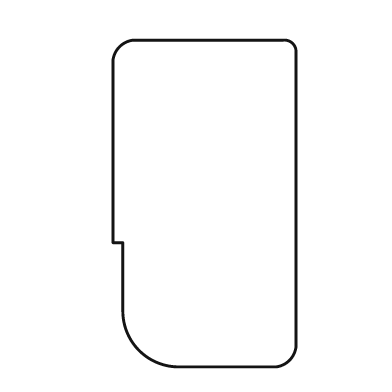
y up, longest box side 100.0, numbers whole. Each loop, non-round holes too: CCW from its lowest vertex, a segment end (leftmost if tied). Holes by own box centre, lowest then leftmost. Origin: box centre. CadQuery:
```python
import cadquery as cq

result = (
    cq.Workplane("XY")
    .moveTo(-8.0, -50.0)
    .lineTo(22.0, -50.0)
    .threePointArc((26.0, -48.0), (28.0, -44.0))
    .lineTo(28.0, 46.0)
    .threePointArc((27.0, 49.0), (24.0, 50.0))
    .lineTo(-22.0, 50.0)
    .threePointArc((-26.0, 48.0), (-28.0, 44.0))
    .lineTo(-28.0, -12.0)
    .lineTo(-25.0, -12.0)
    .lineTo(-25.0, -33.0)
    .threePointArc((-20.0, -45.0), (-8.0, -50.0))
    .close()
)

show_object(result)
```